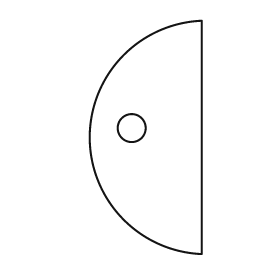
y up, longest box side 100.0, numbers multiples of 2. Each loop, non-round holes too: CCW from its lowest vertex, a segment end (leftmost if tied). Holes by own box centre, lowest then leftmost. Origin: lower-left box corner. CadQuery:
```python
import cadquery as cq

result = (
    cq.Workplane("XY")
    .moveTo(48.0, 0.0)
    .lineTo(48.0, 100.0)
    .threePointArc((0.0, 50.0), (48.0, 0.0))
    .close()
    .moveTo(18.0, 54.0)
    .circle(6.0)
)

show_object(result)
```